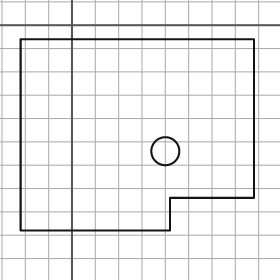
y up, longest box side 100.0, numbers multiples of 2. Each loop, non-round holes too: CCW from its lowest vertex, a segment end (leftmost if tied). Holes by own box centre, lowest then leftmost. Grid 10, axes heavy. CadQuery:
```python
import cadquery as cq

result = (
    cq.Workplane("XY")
    .moveTo(-22.0, -88.0)
    .lineTo(42.0, -88.0)
    .lineTo(42.0, -74.0)
    .lineTo(78.0, -74.0)
    .lineTo(78.0, -6.0)
    .lineTo(-22.0, -6.0)
    .close()
    .moveTo(40.0, -54.0)
    .circle(6.0)
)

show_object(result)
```